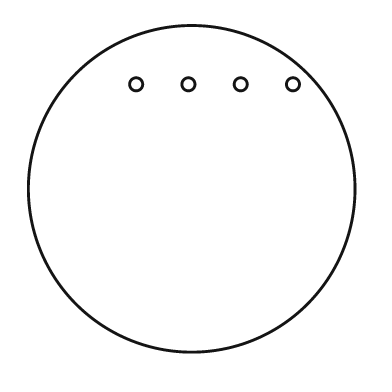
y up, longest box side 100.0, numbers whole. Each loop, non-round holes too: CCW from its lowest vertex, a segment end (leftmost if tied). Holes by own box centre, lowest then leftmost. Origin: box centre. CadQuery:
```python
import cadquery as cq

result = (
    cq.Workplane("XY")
    .moveTo(0.0, 0.0)
    .circle(50.0)
    .moveTo(-17.0, 32.0)
    .circle(2.0)
    .moveTo(-1.0, 32.0)
    .circle(2.0)
    .moveTo(15.0, 32.0)
    .circle(2.0)
    .moveTo(31.0, 32.0)
    .circle(2.0)
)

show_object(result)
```